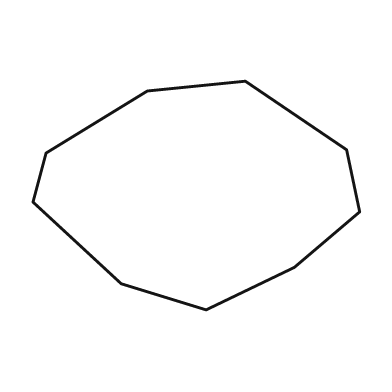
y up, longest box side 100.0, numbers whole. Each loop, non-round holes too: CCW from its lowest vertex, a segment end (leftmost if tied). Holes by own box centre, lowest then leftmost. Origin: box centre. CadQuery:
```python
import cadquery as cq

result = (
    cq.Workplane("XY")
    .moveTo(3.0, -35.0)
    .lineTo(30.0, -22.0)
    .lineTo(50.0, -5.0)
    .lineTo(46.0, 14.0)
    .lineTo(15.0, 35.0)
    .lineTo(-15.0, 32.0)
    .lineTo(-46.0, 13.0)
    .lineTo(-50.0, -2.0)
    .lineTo(-23.0, -27.0)
    .close()
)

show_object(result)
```